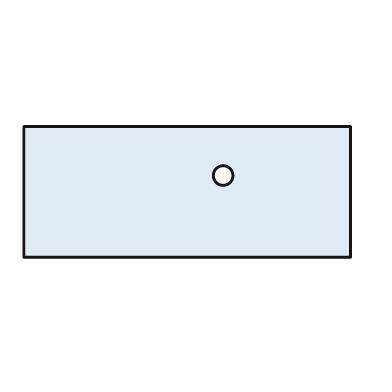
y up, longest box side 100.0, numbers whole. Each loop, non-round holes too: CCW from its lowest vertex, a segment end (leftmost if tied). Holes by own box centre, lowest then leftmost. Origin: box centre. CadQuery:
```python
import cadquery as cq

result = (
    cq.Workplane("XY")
    .moveTo(-50.0, -20.0)
    .lineTo(50.0, -20.0)
    .lineTo(50.0, 20.0)
    .lineTo(-50.0, 20.0)
    .close()
    .moveTo(11.0, 5.0)
    .circle(3.0)
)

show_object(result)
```